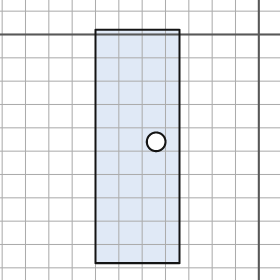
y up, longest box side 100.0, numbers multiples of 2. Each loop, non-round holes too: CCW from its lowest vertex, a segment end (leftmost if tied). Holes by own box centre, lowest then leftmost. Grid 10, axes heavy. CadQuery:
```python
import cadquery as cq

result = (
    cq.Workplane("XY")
    .moveTo(-70.0, -98.0)
    .lineTo(-34.0, -98.0)
    .lineTo(-34.0, 2.0)
    .lineTo(-70.0, 2.0)
    .close()
    .moveTo(-44.0, -46.0)
    .circle(4.0)
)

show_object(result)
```